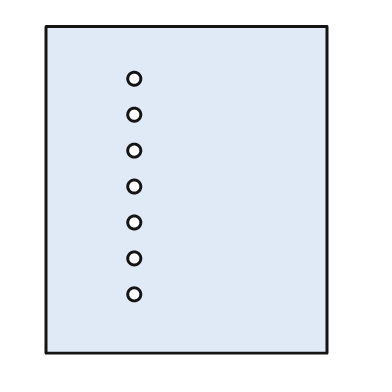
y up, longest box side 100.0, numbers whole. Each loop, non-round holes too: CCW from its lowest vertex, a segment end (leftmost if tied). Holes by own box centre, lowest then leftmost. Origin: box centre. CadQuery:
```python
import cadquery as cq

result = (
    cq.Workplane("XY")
    .moveTo(-43.0, -50.0)
    .lineTo(43.0, -50.0)
    .lineTo(43.0, 50.0)
    .lineTo(-43.0, 50.0)
    .close()
    .moveTo(-16.0, -32.0)
    .circle(2.0)
    .moveTo(-16.0, -21.0)
    .circle(2.0)
    .moveTo(-16.0, -10.0)
    .circle(2.0)
    .moveTo(-16.0, 1.0)
    .circle(2.0)
    .moveTo(-16.0, 12.0)
    .circle(2.0)
    .moveTo(-16.0, 23.0)
    .circle(2.0)
    .moveTo(-16.0, 34.0)
    .circle(2.0)
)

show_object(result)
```